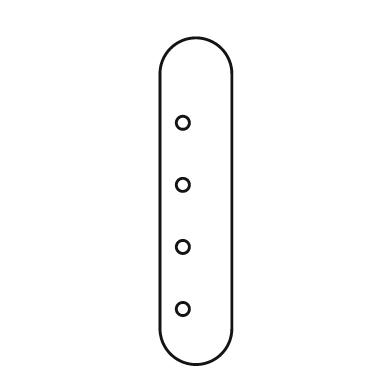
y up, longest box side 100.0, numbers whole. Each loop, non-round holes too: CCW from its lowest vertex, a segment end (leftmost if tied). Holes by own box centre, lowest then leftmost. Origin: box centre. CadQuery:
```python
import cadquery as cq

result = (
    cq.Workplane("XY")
    .moveTo(-11.0, -39.0)
    .threePointArc((0.0, -50.0), (11.0, -39.0))
    .lineTo(11.0, 39.0)
    .threePointArc((0.0, 50.0), (-11.0, 39.0))
    .close()
    .moveTo(-4.0, -33.0)
    .circle(2.0)
    .moveTo(-4.0, -14.0)
    .circle(2.0)
    .moveTo(-4.0, 5.0)
    .circle(2.0)
    .moveTo(-4.0, 24.0)
    .circle(2.0)
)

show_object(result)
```